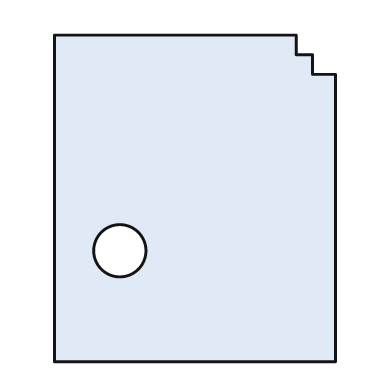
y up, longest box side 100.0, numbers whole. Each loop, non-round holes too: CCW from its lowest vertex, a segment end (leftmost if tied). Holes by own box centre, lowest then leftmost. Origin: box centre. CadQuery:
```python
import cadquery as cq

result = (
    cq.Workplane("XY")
    .moveTo(-43.0, -50.0)
    .lineTo(43.0, -50.0)
    .lineTo(43.0, 38.0)
    .lineTo(36.0, 38.0)
    .lineTo(36.0, 44.0)
    .lineTo(31.0, 44.0)
    .lineTo(31.0, 50.0)
    .lineTo(-43.0, 50.0)
    .close()
    .moveTo(-23.0, -16.0)
    .circle(8.0)
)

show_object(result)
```